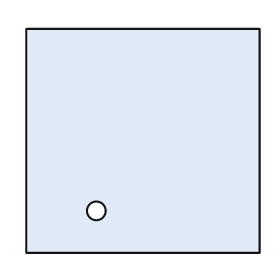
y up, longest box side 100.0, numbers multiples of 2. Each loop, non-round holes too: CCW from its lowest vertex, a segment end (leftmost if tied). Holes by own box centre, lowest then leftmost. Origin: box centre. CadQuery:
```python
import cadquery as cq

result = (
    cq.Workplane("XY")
    .moveTo(-50.0, -48.0)
    .lineTo(50.0, -48.0)
    .lineTo(50.0, 48.0)
    .lineTo(-50.0, 48.0)
    .close()
    .moveTo(-20.0, -30.0)
    .circle(4.0)
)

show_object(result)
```